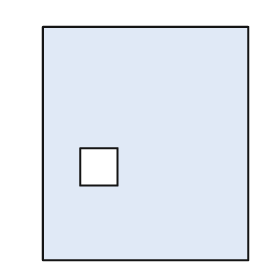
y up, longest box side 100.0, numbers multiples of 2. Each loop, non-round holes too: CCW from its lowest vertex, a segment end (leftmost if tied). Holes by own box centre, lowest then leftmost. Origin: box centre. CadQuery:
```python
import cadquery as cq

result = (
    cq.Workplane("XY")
    .moveTo(-44.0, -50.0)
    .lineTo(44.0, -50.0)
    .lineTo(44.0, 50.0)
    .lineTo(-44.0, 50.0)
    .close()
    .moveTo(-28.0, -18.0)
    .lineTo(-12.0, -18.0)
    .lineTo(-12.0, -2.0)
    .lineTo(-28.0, -2.0)
    .close()
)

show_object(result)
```